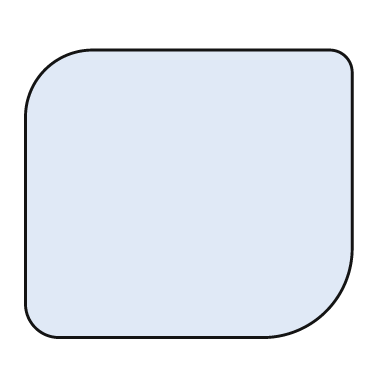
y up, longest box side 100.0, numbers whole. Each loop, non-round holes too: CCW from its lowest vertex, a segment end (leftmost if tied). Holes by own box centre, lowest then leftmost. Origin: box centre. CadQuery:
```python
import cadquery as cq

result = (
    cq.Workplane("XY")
    .moveTo(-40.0, -44.0)
    .lineTo(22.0, -44.0)
    .threePointArc((42.0, -36.0), (50.0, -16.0))
    .lineTo(50.0, 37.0)
    .threePointArc((48.0, 42.0), (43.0, 44.0))
    .lineTo(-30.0, 44.0)
    .threePointArc((-44.0, 38.0), (-50.0, 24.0))
    .lineTo(-50.0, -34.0)
    .threePointArc((-47.0, -41.0), (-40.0, -44.0))
    .close()
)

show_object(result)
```